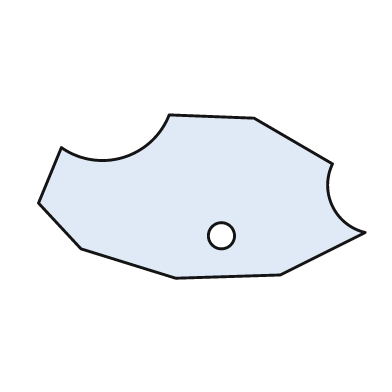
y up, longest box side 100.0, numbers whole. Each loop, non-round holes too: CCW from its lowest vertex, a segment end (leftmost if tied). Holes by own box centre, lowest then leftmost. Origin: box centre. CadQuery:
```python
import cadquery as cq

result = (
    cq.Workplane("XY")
    .moveTo(-8.0, -25.0)
    .lineTo(24.0, -24.0)
    .lineTo(50.0, -11.0)
    .threePointArc((40.0, -3.0), (40.0, 10.0))
    .lineTo(16.0, 24.0)
    .lineTo(-10.0, 25.0)
    .threePointArc((-24.0, 12.0), (-43.0, 15.0))
    .lineTo(-50.0, -2.0)
    .lineTo(-37.0, -16.0)
    .close()
    .moveTo(6.0, -12.0)
    .circle(4.0)
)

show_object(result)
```